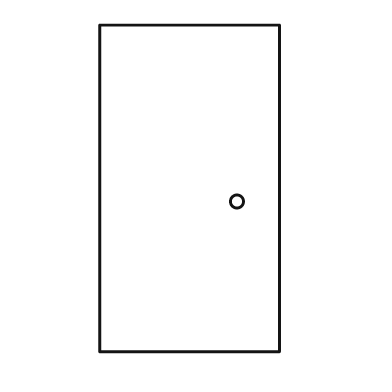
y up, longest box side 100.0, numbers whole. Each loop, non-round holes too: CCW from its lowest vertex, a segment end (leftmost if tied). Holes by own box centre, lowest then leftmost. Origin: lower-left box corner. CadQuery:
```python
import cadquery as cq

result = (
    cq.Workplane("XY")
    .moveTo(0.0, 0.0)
    .lineTo(55.0, 0.0)
    .lineTo(55.0, 100.0)
    .lineTo(0.0, 100.0)
    .close()
    .moveTo(42.0, 46.0)
    .circle(2.0)
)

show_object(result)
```